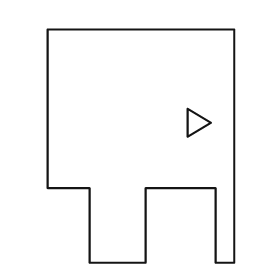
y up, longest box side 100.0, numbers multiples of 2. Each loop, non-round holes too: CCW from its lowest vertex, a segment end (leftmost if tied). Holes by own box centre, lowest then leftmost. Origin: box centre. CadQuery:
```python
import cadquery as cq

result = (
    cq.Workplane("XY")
    .moveTo(-22.0, -50.0)
    .lineTo(2.0, -50.0)
    .lineTo(2.0, -18.0)
    .lineTo(32.0, -18.0)
    .lineTo(32.0, -50.0)
    .lineTo(40.0, -50.0)
    .lineTo(40.0, 50.0)
    .lineTo(-40.0, 50.0)
    .lineTo(-40.0, -18.0)
    .lineTo(-22.0, -18.0)
    .close()
    .moveTo(20.0, 4.0)
    .lineTo(30.0, 10.0)
    .lineTo(20.0, 16.0)
    .close()
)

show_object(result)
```